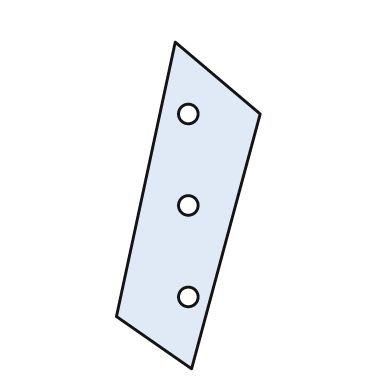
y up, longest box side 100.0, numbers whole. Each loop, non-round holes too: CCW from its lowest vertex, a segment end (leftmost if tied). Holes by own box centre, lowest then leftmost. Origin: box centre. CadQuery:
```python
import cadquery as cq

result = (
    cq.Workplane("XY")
    .moveTo(1.0, -50.0)
    .lineTo(22.0, 28.0)
    .lineTo(-4.0, 50.0)
    .lineTo(-22.0, -34.0)
    .close()
    .moveTo(0.0, -28.0)
    .circle(3.0)
    .moveTo(0.0, 0.0)
    .circle(3.0)
    .moveTo(0.0, 28.0)
    .circle(3.0)
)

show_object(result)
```